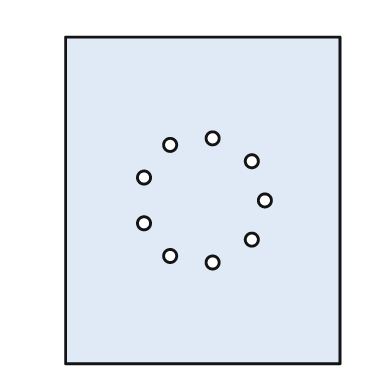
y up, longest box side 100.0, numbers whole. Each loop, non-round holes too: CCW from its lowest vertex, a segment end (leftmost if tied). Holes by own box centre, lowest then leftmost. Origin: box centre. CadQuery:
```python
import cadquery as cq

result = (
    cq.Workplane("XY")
    .moveTo(-42.0, -50.0)
    .lineTo(42.0, -50.0)
    .lineTo(42.0, 50.0)
    .lineTo(-42.0, 50.0)
    .close()
    .moveTo(3.0, -19.0)
    .circle(2.0)
    .moveTo(-10.0, -17.0)
    .circle(2.0)
    .moveTo(15.0, -12.0)
    .circle(2.0)
    .moveTo(-18.0, -7.0)
    .circle(2.0)
    .moveTo(19.0, 0.0)
    .circle(2.0)
    .moveTo(-18.0, 7.0)
    .circle(2.0)
    .moveTo(15.0, 12.0)
    .circle(2.0)
    .moveTo(-10.0, 17.0)
    .circle(2.0)
    .moveTo(3.0, 19.0)
    .circle(2.0)
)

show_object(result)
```